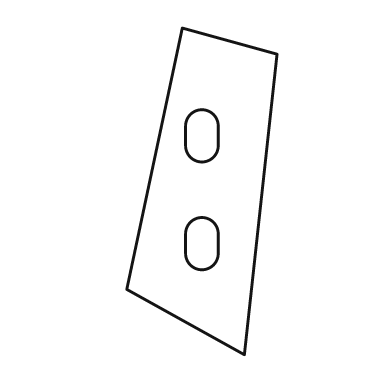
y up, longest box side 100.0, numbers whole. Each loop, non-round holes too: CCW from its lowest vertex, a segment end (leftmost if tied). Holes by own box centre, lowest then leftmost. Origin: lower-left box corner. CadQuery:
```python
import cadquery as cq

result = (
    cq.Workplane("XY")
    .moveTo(36.0, 0.0)
    .lineTo(46.0, 92.0)
    .lineTo(17.0, 100.0)
    .lineTo(0.0, 20.0)
    .close()
    .moveTo(18.0, 31.0)
    .threePointArc((23.0, 26.0), (28.0, 31.0))
    .lineTo(28.0, 37.0)
    .threePointArc((23.0, 42.0), (18.0, 37.0))
    .close()
    .moveTo(18.0, 64.0)
    .threePointArc((23.0, 59.0), (28.0, 64.0))
    .lineTo(28.0, 70.0)
    .threePointArc((23.0, 75.0), (18.0, 70.0))
    .close()
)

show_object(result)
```